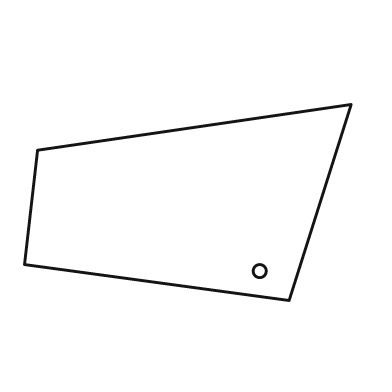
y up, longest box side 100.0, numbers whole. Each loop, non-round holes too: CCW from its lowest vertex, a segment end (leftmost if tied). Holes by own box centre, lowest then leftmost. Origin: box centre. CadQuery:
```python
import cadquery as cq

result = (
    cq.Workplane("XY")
    .moveTo(31.0, -30.0)
    .lineTo(50.0, 30.0)
    .lineTo(-46.0, 16.0)
    .lineTo(-50.0, -19.0)
    .close()
    .moveTo(22.0, -21.0)
    .circle(2.0)
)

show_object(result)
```